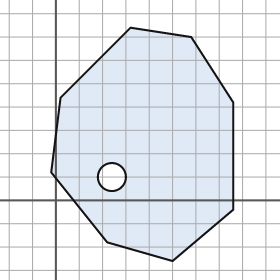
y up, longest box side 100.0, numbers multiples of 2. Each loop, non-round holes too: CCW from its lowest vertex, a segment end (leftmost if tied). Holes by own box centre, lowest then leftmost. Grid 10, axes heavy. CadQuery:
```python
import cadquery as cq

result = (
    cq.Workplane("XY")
    .moveTo(50.0, -26.0)
    .lineTo(76.0, -4.0)
    .lineTo(76.0, 42.0)
    .lineTo(58.0, 70.0)
    .lineTo(32.0, 74.0)
    .lineTo(2.0, 44.0)
    .lineTo(-2.0, 12.0)
    .lineTo(22.0, -18.0)
    .close()
    .moveTo(24.0, 10.0)
    .circle(6.0)
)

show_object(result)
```